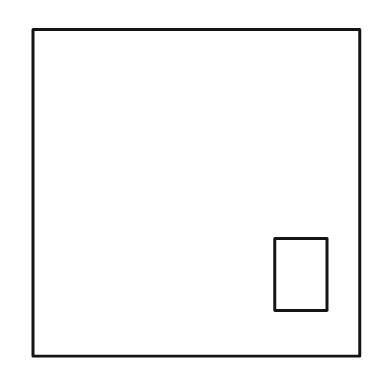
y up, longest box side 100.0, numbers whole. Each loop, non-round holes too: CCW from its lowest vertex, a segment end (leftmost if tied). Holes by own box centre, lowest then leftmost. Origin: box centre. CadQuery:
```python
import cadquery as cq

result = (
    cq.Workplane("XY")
    .moveTo(-50.0, -50.0)
    .lineTo(50.0, -50.0)
    .lineTo(50.0, 50.0)
    .lineTo(-50.0, 50.0)
    .close()
    .moveTo(24.0, -36.0)
    .lineTo(40.0, -36.0)
    .lineTo(40.0, -14.0)
    .lineTo(24.0, -14.0)
    .close()
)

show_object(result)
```